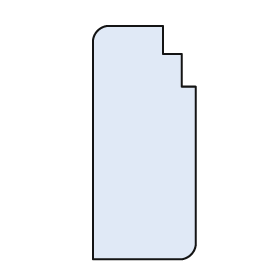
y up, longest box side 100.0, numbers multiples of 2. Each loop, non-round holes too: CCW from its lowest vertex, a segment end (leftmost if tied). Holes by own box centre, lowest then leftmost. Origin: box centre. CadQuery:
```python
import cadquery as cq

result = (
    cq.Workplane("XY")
    .moveTo(-22.0, -50.0)
    .lineTo(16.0, -50.0)
    .threePointArc((20.0, -48.0), (22.0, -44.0))
    .lineTo(22.0, 24.0)
    .lineTo(16.0, 24.0)
    .lineTo(16.0, 38.0)
    .lineTo(8.0, 38.0)
    .lineTo(8.0, 50.0)
    .lineTo(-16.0, 50.0)
    .threePointArc((-20.0, 48.0), (-22.0, 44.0))
    .close()
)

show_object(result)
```